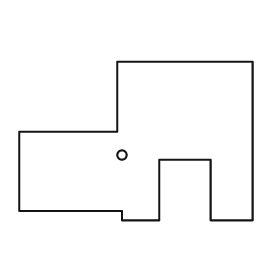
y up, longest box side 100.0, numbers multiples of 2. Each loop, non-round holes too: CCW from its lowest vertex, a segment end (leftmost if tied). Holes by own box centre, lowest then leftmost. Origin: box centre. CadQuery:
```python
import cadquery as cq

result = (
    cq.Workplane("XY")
    .moveTo(-6.0, -34.0)
    .lineTo(10.0, -34.0)
    .lineTo(10.0, -8.0)
    .lineTo(32.0, -8.0)
    .lineTo(32.0, -34.0)
    .lineTo(50.0, -34.0)
    .lineTo(50.0, 34.0)
    .lineTo(-8.0, 34.0)
    .lineTo(-8.0, 4.0)
    .lineTo(-50.0, 4.0)
    .lineTo(-50.0, -30.0)
    .lineTo(-6.0, -30.0)
    .close()
    .moveTo(-6.0, -6.0)
    .circle(2.0)
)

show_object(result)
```